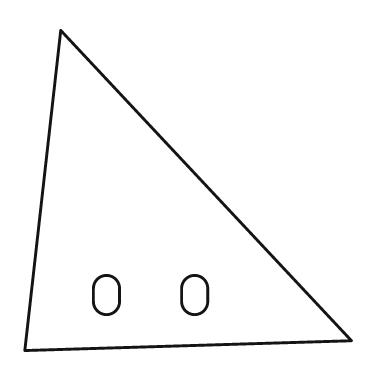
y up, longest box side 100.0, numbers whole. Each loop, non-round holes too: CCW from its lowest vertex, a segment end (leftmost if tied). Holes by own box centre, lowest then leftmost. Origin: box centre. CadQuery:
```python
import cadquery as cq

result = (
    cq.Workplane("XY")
    .moveTo(-50.0, -49.0)
    .lineTo(50.0, -46.0)
    .lineTo(-39.0, 49.0)
    .close()
    .moveTo(-29.0, -34.0)
    .threePointArc((-25.0, -38.0), (-21.0, -34.0))
    .lineTo(-21.0, -30.0)
    .threePointArc((-25.0, -26.0), (-29.0, -30.0))
    .close()
    .moveTo(-2.0, -34.0)
    .threePointArc((2.0, -38.0), (6.0, -34.0))
    .lineTo(6.0, -30.0)
    .threePointArc((2.0, -26.0), (-2.0, -30.0))
    .close()
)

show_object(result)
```